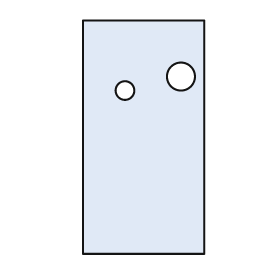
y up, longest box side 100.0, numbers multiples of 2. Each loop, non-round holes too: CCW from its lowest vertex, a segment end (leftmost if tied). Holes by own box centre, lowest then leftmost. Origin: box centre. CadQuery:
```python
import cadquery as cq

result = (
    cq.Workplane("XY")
    .moveTo(-26.0, -50.0)
    .lineTo(26.0, -50.0)
    .lineTo(26.0, 50.0)
    .lineTo(-26.0, 50.0)
    .close()
    .moveTo(-8.0, 20.0)
    .circle(4.0)
    .moveTo(16.0, 26.0)
    .circle(6.0)
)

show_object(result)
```